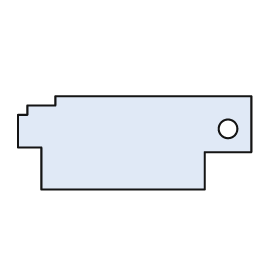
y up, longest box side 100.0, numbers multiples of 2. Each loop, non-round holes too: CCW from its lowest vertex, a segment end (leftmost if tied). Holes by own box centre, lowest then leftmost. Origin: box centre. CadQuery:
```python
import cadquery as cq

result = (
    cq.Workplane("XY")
    .moveTo(-40.0, -20.0)
    .lineTo(30.0, -20.0)
    .lineTo(30.0, -4.0)
    .lineTo(50.0, -4.0)
    .lineTo(50.0, 20.0)
    .lineTo(-34.0, 20.0)
    .lineTo(-34.0, 16.0)
    .lineTo(-46.0, 16.0)
    .lineTo(-46.0, 12.0)
    .lineTo(-50.0, 12.0)
    .lineTo(-50.0, -2.0)
    .lineTo(-40.0, -2.0)
    .close()
    .moveTo(40.0, 6.0)
    .circle(4.0)
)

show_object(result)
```